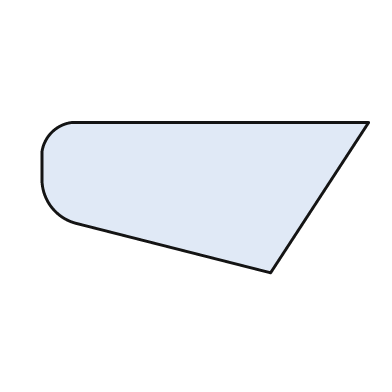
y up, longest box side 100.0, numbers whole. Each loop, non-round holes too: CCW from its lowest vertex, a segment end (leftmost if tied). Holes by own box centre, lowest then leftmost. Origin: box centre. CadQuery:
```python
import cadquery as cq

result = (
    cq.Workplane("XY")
    .moveTo(20.0, -23.0)
    .lineTo(50.0, 23.0)
    .lineTo(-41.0, 23.0)
    .threePointArc((-47.0, 20.0), (-50.0, 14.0))
    .lineTo(-50.0, 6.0)
    .threePointArc((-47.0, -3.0), (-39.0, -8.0))
    .close()
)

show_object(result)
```